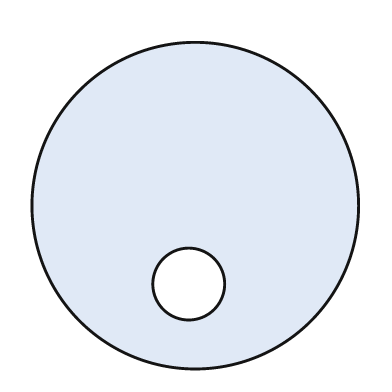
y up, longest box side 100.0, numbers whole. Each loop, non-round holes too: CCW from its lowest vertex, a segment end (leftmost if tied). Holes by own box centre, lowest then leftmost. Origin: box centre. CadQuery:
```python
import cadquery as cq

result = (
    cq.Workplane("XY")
    .moveTo(0.0, 0.0)
    .circle(50.0)
    .moveTo(-2.0, -24.0)
    .circle(11.0)
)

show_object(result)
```